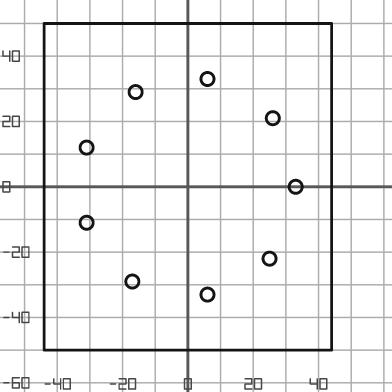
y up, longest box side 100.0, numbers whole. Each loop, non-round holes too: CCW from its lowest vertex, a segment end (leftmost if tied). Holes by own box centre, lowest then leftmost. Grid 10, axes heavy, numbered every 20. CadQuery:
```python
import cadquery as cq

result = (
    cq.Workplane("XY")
    .moveTo(-44.0, -50.0)
    .lineTo(44.0, -50.0)
    .lineTo(44.0, 50.0)
    .lineTo(-44.0, 50.0)
    .close()
    .moveTo(6.0, -33.0)
    .circle(2.0)
    .moveTo(-17.0, -29.0)
    .circle(2.0)
    .moveTo(25.0, -22.0)
    .circle(2.0)
    .moveTo(-31.0, -11.0)
    .circle(2.0)
    .moveTo(33.0, 0.0)
    .circle(2.0)
    .moveTo(-31.0, 12.0)
    .circle(2.0)
    .moveTo(26.0, 21.0)
    .circle(2.0)
    .moveTo(-16.0, 29.0)
    .circle(2.0)
    .moveTo(6.0, 33.0)
    .circle(2.0)
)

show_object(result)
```